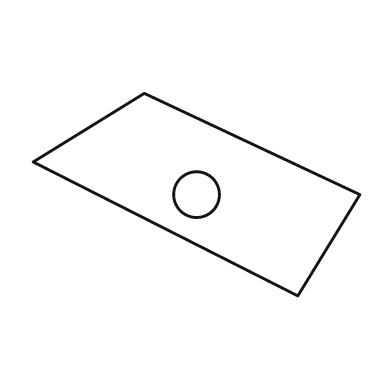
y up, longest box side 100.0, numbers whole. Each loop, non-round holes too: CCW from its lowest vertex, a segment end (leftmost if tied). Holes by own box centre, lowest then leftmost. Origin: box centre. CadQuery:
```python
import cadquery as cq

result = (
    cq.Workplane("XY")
    .moveTo(31.0, -31.0)
    .lineTo(50.0, 0.0)
    .lineTo(-16.0, 31.0)
    .lineTo(-50.0, 10.0)
    .close()
    .moveTo(0.0, 0.0)
    .circle(7.0)
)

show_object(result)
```